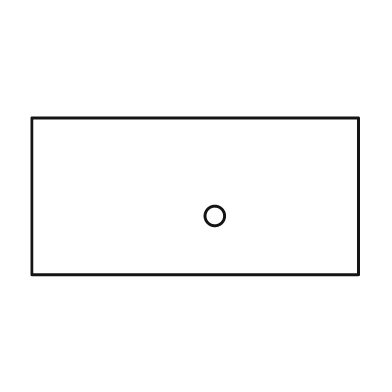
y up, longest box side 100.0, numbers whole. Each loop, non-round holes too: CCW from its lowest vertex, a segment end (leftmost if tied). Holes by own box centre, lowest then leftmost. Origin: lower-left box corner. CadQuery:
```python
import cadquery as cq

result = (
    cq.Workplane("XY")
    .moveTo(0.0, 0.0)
    .lineTo(100.0, 0.0)
    .lineTo(100.0, 48.0)
    .lineTo(0.0, 48.0)
    .close()
    .moveTo(56.0, 18.0)
    .circle(3.0)
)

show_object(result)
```